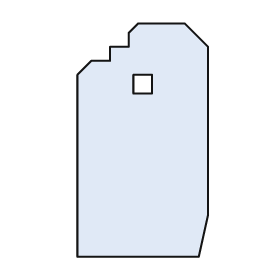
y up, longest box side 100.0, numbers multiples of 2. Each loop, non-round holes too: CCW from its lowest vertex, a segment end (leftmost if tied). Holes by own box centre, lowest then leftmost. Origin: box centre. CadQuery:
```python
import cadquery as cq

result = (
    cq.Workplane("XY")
    .moveTo(-28.0, -50.0)
    .lineTo(24.0, -50.0)
    .lineTo(28.0, -32.0)
    .lineTo(28.0, 40.0)
    .lineTo(18.0, 50.0)
    .lineTo(-2.0, 50.0)
    .lineTo(-6.0, 46.0)
    .lineTo(-6.0, 40.0)
    .lineTo(-14.0, 40.0)
    .lineTo(-14.0, 34.0)
    .lineTo(-22.0, 34.0)
    .lineTo(-28.0, 28.0)
    .close()
    .moveTo(-4.0, 20.0)
    .lineTo(4.0, 20.0)
    .lineTo(4.0, 28.0)
    .lineTo(-4.0, 28.0)
    .close()
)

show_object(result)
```